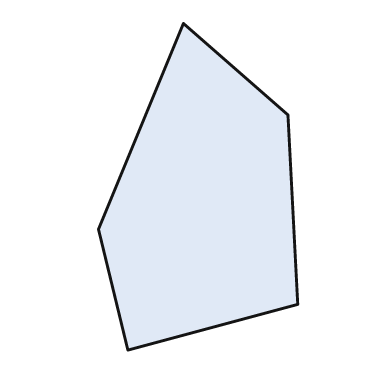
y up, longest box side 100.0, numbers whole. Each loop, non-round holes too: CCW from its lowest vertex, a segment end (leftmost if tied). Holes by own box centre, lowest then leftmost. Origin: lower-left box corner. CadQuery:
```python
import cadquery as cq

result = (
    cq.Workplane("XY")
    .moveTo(9.0, 0.0)
    .lineTo(61.0, 14.0)
    .lineTo(58.0, 72.0)
    .lineTo(26.0, 100.0)
    .lineTo(0.0, 37.0)
    .close()
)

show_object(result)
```